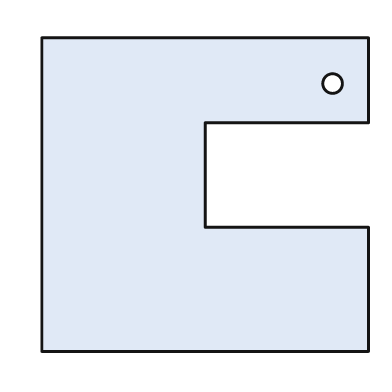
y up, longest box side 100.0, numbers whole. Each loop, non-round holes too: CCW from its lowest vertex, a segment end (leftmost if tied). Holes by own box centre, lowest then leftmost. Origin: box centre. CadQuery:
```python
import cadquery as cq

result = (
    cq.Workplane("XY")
    .moveTo(-50.0, -48.0)
    .lineTo(50.0, -48.0)
    .lineTo(50.0, -10.0)
    .lineTo(0.0, -10.0)
    .lineTo(0.0, 22.0)
    .lineTo(50.0, 22.0)
    .lineTo(50.0, 48.0)
    .lineTo(-50.0, 48.0)
    .close()
    .moveTo(39.0, 34.0)
    .circle(3.0)
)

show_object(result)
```